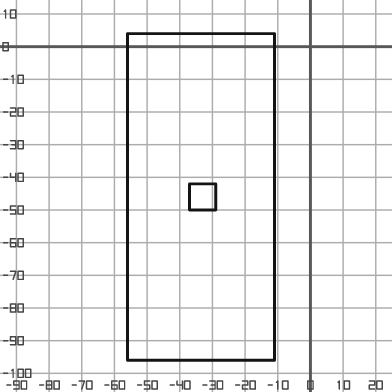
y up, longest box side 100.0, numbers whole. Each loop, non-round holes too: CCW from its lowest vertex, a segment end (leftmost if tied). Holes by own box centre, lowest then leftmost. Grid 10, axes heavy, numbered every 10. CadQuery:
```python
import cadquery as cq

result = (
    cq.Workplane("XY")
    .moveTo(-56.0, -96.0)
    .lineTo(-11.0, -96.0)
    .lineTo(-11.0, 4.0)
    .lineTo(-56.0, 4.0)
    .close()
    .moveTo(-37.0, -50.0)
    .lineTo(-29.0, -50.0)
    .lineTo(-29.0, -42.0)
    .lineTo(-37.0, -42.0)
    .close()
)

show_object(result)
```